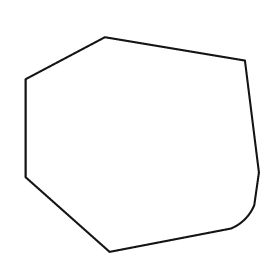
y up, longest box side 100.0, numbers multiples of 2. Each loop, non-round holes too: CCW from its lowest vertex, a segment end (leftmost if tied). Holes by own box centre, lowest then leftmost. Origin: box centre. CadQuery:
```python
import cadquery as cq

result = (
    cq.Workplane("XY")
    .moveTo(-14.0, -46.0)
    .lineTo(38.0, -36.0)
    .threePointArc((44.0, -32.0), (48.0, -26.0))
    .lineTo(50.0, -12.0)
    .lineTo(44.0, 36.0)
    .lineTo(-16.0, 46.0)
    .lineTo(-50.0, 28.0)
    .lineTo(-50.0, -14.0)
    .close()
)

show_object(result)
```